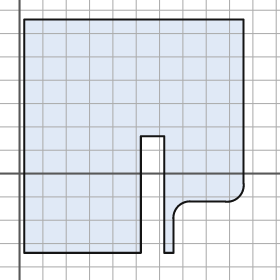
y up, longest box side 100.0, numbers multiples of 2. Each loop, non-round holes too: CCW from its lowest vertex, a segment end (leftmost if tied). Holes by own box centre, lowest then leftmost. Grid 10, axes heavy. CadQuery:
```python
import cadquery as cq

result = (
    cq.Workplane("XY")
    .moveTo(2.0, -34.0)
    .lineTo(52.0, -34.0)
    .lineTo(52.0, 16.0)
    .lineTo(62.0, 16.0)
    .lineTo(62.0, -34.0)
    .lineTo(66.0, -34.0)
    .lineTo(66.0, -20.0)
    .threePointArc((68.0, -14.0), (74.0, -12.0))
    .lineTo(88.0, -12.0)
    .threePointArc((94.0, -10.0), (96.0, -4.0))
    .lineTo(96.0, 66.0)
    .lineTo(2.0, 66.0)
    .close()
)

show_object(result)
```